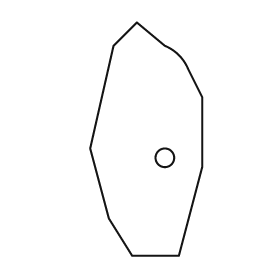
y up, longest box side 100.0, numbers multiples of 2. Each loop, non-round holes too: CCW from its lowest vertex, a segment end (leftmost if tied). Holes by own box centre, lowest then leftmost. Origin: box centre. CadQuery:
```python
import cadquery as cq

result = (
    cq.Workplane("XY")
    .moveTo(-6.0, -50.0)
    .lineTo(14.0, -50.0)
    .lineTo(24.0, -12.0)
    .lineTo(24.0, 18.0)
    .lineTo(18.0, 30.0)
    .threePointArc((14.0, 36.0), (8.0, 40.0))
    .lineTo(-4.0, 50.0)
    .lineTo(-14.0, 40.0)
    .lineTo(-24.0, -4.0)
    .lineTo(-16.0, -34.0)
    .close()
    .moveTo(8.0, -8.0)
    .circle(4.0)
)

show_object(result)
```